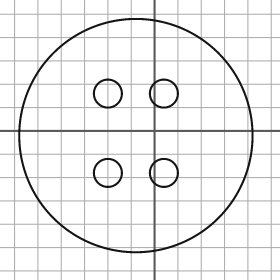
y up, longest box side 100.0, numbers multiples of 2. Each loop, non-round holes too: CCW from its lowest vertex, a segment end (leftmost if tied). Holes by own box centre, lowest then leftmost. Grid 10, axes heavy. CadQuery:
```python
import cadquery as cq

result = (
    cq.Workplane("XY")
    .moveTo(-8.0, -2.0)
    .circle(50.0)
    .moveTo(-20.0, -18.0)
    .circle(6.0)
    .moveTo(4.0, -18.0)
    .circle(6.0)
    .moveTo(-20.0, 16.0)
    .circle(6.0)
    .moveTo(4.0, 16.0)
    .circle(6.0)
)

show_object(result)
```